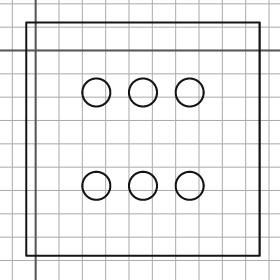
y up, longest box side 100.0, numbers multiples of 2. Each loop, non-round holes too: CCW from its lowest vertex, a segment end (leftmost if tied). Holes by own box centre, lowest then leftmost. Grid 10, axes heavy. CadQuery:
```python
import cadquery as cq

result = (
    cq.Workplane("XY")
    .moveTo(-4.0, -88.0)
    .lineTo(96.0, -88.0)
    .lineTo(96.0, 12.0)
    .lineTo(-4.0, 12.0)
    .close()
    .moveTo(26.0, -58.0)
    .circle(6.0)
    .moveTo(46.0, -58.0)
    .circle(6.0)
    .moveTo(66.0, -58.0)
    .circle(6.0)
    .moveTo(26.0, -18.0)
    .circle(6.0)
    .moveTo(46.0, -18.0)
    .circle(6.0)
    .moveTo(66.0, -18.0)
    .circle(6.0)
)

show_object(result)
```